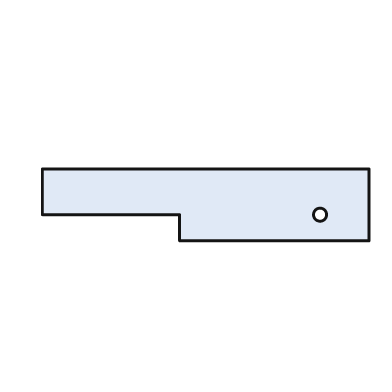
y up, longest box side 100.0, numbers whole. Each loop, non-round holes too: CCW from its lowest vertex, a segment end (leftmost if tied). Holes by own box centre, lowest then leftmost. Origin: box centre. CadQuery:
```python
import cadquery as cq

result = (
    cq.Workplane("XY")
    .moveTo(-8.0, -11.0)
    .lineTo(50.0, -11.0)
    .lineTo(50.0, 11.0)
    .lineTo(-50.0, 11.0)
    .lineTo(-50.0, -3.0)
    .lineTo(-8.0, -3.0)
    .close()
    .moveTo(35.0, -3.0)
    .circle(2.0)
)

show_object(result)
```